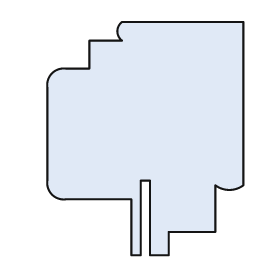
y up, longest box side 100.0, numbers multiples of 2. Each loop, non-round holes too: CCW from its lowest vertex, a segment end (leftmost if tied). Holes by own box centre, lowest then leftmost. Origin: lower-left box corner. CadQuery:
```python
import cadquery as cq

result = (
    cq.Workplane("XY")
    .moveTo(36.0, 0.0)
    .lineTo(40.0, 0.0)
    .lineTo(40.0, 32.0)
    .lineTo(44.0, 32.0)
    .lineTo(44.0, 0.0)
    .lineTo(52.0, 0.0)
    .lineTo(52.0, 10.0)
    .lineTo(72.0, 10.0)
    .lineTo(72.0, 30.0)
    .threePointArc((78.0, 28.0), (84.0, 30.0))
    .lineTo(84.0, 100.0)
    .lineTo(32.0, 100.0)
    .threePointArc((30.0, 96.0), (32.0, 92.0))
    .lineTo(18.0, 92.0)
    .lineTo(18.0, 80.0)
    .lineTo(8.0, 80.0)
    .threePointArc((2.0, 78.0), (0.0, 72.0))
    .lineTo(0.0, 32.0)
    .threePointArc((2.0, 26.0), (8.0, 24.0))
    .lineTo(36.0, 24.0)
    .close()
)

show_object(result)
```